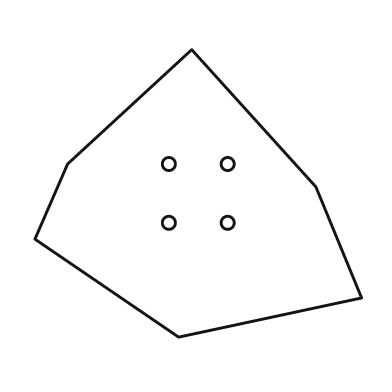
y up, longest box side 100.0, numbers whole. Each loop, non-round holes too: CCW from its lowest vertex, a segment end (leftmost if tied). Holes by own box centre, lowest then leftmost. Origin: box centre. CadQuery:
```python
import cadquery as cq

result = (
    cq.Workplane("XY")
    .moveTo(-6.0, -44.0)
    .lineTo(50.0, -32.0)
    .lineTo(36.0, 2.0)
    .lineTo(-2.0, 44.0)
    .lineTo(-40.0, 9.0)
    .lineTo(-50.0, -14.0)
    .close()
    .moveTo(-9.0, -9.0)
    .circle(2.0)
    .moveTo(9.0, -9.0)
    .circle(2.0)
    .moveTo(-9.0, 9.0)
    .circle(2.0)
    .moveTo(9.0, 9.0)
    .circle(2.0)
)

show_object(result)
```